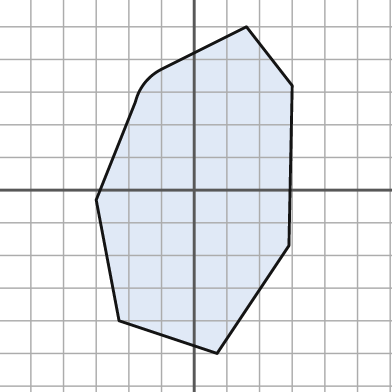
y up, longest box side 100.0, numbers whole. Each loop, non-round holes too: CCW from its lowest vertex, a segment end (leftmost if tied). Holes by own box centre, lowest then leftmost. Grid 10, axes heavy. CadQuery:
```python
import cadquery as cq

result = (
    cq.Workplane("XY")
    .moveTo(7.0, -50.0)
    .lineTo(29.0, -17.0)
    .lineTo(30.0, 32.0)
    .lineTo(16.0, 50.0)
    .lineTo(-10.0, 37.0)
    .threePointArc((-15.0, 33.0), (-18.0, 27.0))
    .lineTo(-30.0, -3.0)
    .lineTo(-23.0, -40.0)
    .close()
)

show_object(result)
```